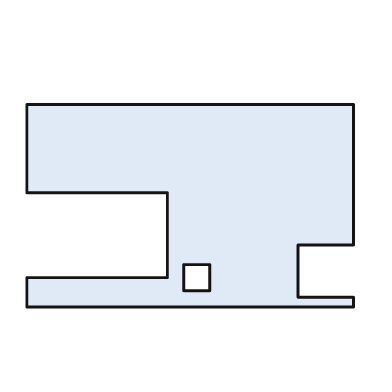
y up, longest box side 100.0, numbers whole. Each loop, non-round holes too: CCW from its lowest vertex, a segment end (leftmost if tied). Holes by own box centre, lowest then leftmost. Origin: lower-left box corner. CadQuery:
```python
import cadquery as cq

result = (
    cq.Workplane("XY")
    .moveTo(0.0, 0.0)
    .lineTo(100.0, 0.0)
    .lineTo(100.0, 3.0)
    .lineTo(83.0, 3.0)
    .lineTo(83.0, 19.0)
    .lineTo(100.0, 19.0)
    .lineTo(100.0, 62.0)
    .lineTo(0.0, 62.0)
    .lineTo(0.0, 35.0)
    .lineTo(43.0, 35.0)
    .lineTo(43.0, 9.0)
    .lineTo(0.0, 9.0)
    .close()
    .moveTo(48.0, 5.0)
    .lineTo(56.0, 5.0)
    .lineTo(56.0, 13.0)
    .lineTo(48.0, 13.0)
    .close()
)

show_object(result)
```